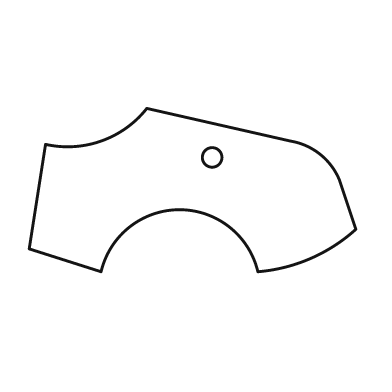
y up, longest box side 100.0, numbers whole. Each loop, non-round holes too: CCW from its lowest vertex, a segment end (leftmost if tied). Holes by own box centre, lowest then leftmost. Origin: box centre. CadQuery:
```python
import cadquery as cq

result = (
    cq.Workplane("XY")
    .moveTo(-28.0, -25.0)
    .threePointArc((-4.0, -6.0), (20.0, -25.0))
    .threePointArc((36.0, -21.0), (50.0, -12.0))
    .lineTo(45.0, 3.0)
    .threePointArc((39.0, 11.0), (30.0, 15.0))
    .lineTo(-14.0, 25.0)
    .threePointArc((-28.0, 15.0), (-45.0, 14.0))
    .lineTo(-50.0, -18.0)
    .close()
    .moveTo(6.0, 10.0)
    .circle(3.0)
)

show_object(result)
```